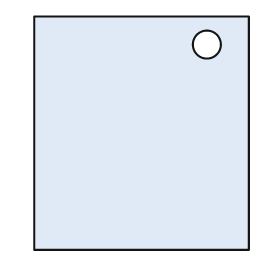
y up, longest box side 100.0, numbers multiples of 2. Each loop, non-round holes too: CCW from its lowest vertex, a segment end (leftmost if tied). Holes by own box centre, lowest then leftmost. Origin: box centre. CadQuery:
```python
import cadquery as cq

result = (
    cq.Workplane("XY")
    .moveTo(-46.0, -50.0)
    .lineTo(46.0, -50.0)
    .lineTo(46.0, 50.0)
    .lineTo(-46.0, 50.0)
    .close()
    .moveTo(28.0, 38.0)
    .circle(6.0)
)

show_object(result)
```